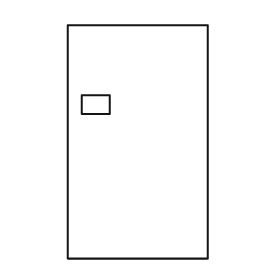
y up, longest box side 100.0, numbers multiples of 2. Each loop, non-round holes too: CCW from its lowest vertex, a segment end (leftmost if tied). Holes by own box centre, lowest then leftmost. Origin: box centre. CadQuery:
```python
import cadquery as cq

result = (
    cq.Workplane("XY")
    .moveTo(-30.0, -50.0)
    .lineTo(30.0, -50.0)
    .lineTo(30.0, 50.0)
    .lineTo(-30.0, 50.0)
    .close()
    .moveTo(-24.0, 12.0)
    .lineTo(-12.0, 12.0)
    .lineTo(-12.0, 20.0)
    .lineTo(-24.0, 20.0)
    .close()
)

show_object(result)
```